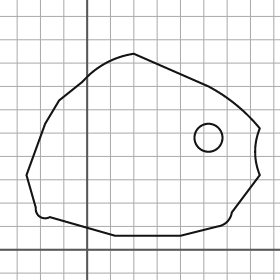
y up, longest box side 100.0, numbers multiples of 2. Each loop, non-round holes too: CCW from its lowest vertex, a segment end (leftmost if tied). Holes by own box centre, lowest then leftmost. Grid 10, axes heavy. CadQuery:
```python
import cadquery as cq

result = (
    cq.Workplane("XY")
    .moveTo(12.0, 6.0)
    .lineTo(40.0, 6.0)
    .lineTo(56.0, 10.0)
    .threePointArc((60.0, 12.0), (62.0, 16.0))
    .lineTo(74.0, 32.0)
    .threePointArc((72.0, 42.0), (74.0, 52.0))
    .threePointArc((64.0, 62.0), (52.0, 70.0))
    .lineTo(20.0, 84.0)
    .threePointArc((8.0, 80.0), (-2.0, 72.0))
    .lineTo(-12.0, 64.0)
    .lineTo(-18.0, 54.0)
    .lineTo(-26.0, 32.0)
    .lineTo(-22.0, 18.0)
    .threePointArc((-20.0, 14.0), (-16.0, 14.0))
    .close()
    .moveTo(52.0, 48.0)
    .circle(6.0)
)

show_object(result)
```